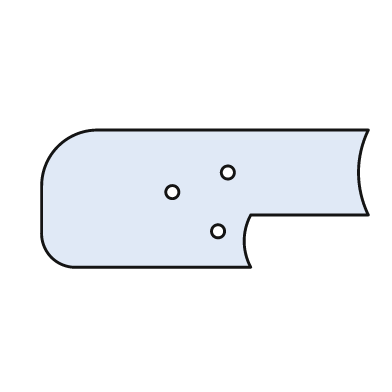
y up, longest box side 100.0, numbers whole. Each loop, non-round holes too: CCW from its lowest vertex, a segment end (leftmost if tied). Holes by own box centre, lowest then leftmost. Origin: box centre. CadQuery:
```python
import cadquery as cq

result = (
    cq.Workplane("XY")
    .moveTo(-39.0, -21.0)
    .lineTo(14.0, -21.0)
    .threePointArc((12.0, -13.0), (14.0, -5.0))
    .lineTo(50.0, -5.0)
    .threePointArc((47.0, 8.0), (50.0, 21.0))
    .lineTo(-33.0, 21.0)
    .threePointArc((-45.0, 16.0), (-50.0, 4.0))
    .lineTo(-50.0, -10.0)
    .threePointArc((-47.0, -18.0), (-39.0, -21.0))
    .close()
    .moveTo(4.0, -10.0)
    .circle(2.0)
    .moveTo(-10.0, 2.0)
    .circle(2.0)
    .moveTo(7.0, 8.0)
    .circle(2.0)
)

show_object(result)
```